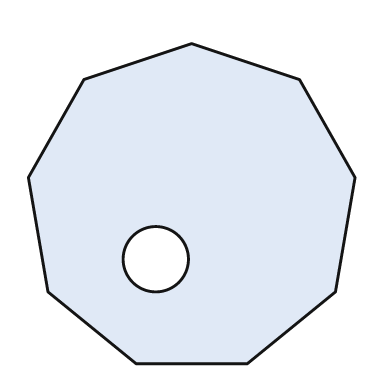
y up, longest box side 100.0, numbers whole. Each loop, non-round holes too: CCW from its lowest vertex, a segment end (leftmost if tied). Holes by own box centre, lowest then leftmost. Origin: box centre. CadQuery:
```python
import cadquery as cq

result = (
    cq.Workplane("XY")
    .moveTo(-17.0, -49.0)
    .lineTo(17.0, -49.0)
    .lineTo(44.0, -27.0)
    .lineTo(50.0, 8.0)
    .lineTo(33.0, 38.0)
    .lineTo(0.0, 49.0)
    .lineTo(-33.0, 38.0)
    .lineTo(-50.0, 8.0)
    .lineTo(-44.0, -27.0)
    .close()
    .moveTo(-11.0, -17.0)
    .circle(10.0)
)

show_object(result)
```